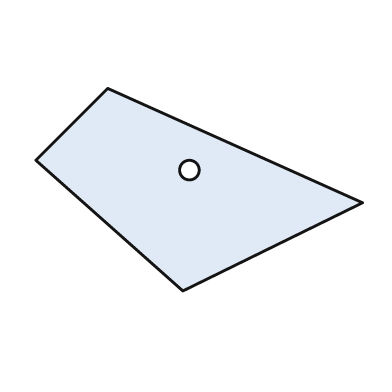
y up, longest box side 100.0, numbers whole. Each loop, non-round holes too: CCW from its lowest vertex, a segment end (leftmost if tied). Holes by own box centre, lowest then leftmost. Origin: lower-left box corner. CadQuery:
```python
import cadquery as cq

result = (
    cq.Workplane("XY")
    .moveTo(45.0, 0.0)
    .lineTo(100.0, 27.0)
    .lineTo(22.0, 62.0)
    .lineTo(0.0, 40.0)
    .close()
    .moveTo(47.0, 37.0)
    .circle(3.0)
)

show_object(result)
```